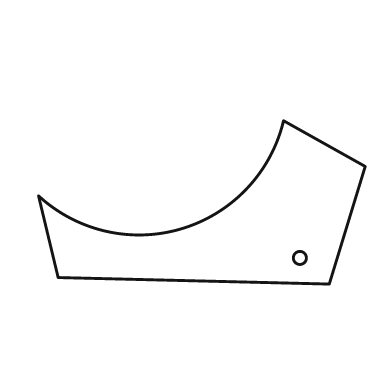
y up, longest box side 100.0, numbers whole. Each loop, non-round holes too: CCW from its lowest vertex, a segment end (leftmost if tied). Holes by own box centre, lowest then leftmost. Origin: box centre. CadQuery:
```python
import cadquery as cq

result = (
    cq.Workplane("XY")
    .moveTo(39.0, -25.0)
    .lineTo(50.0, 11.0)
    .lineTo(25.0, 25.0)
    .threePointArc((-6.0, -8.0), (-50.0, 2.0))
    .lineTo(-44.0, -23.0)
    .close()
    .moveTo(30.0, -17.0)
    .circle(2.0)
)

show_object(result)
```